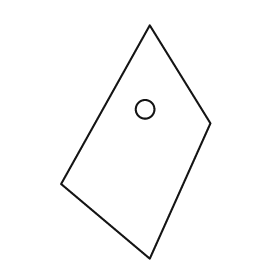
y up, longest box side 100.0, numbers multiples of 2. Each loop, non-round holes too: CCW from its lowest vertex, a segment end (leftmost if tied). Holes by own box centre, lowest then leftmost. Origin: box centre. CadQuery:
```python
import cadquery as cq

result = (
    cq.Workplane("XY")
    .moveTo(6.0, -50.0)
    .lineTo(32.0, 8.0)
    .lineTo(6.0, 50.0)
    .lineTo(-32.0, -18.0)
    .close()
    .moveTo(4.0, 14.0)
    .circle(4.0)
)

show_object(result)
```